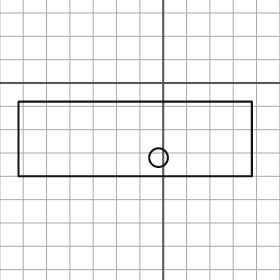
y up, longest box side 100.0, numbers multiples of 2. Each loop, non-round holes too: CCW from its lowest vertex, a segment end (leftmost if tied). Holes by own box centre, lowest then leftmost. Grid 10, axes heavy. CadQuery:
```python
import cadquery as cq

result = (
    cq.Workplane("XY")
    .moveTo(-62.0, -40.0)
    .lineTo(38.0, -40.0)
    .lineTo(38.0, -8.0)
    .lineTo(-62.0, -8.0)
    .close()
    .moveTo(-2.0, -32.0)
    .circle(4.0)
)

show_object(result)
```